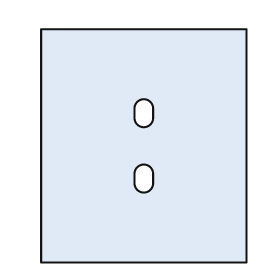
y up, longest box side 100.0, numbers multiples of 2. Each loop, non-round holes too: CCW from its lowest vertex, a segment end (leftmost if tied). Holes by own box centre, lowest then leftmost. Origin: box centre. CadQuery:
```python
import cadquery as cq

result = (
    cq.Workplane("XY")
    .moveTo(-44.0, -50.0)
    .lineTo(44.0, -50.0)
    .lineTo(44.0, 50.0)
    .lineTo(-44.0, 50.0)
    .close()
    .moveTo(-4.0, -16.0)
    .threePointArc((0.0, -20.0), (4.0, -16.0))
    .lineTo(4.0, -12.0)
    .threePointArc((0.0, -8.0), (-4.0, -12.0))
    .close()
    .moveTo(-4.0, 12.0)
    .threePointArc((0.0, 8.0), (4.0, 12.0))
    .lineTo(4.0, 16.0)
    .threePointArc((0.0, 20.0), (-4.0, 16.0))
    .close()
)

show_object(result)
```